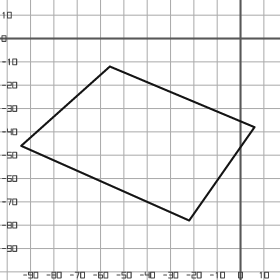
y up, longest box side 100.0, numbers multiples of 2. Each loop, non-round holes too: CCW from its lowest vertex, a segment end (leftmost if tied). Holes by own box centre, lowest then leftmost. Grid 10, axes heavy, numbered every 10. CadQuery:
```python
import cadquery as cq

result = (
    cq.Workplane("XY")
    .moveTo(-22.0, -78.0)
    .lineTo(6.0, -38.0)
    .lineTo(-56.0, -12.0)
    .lineTo(-94.0, -46.0)
    .close()
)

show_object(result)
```